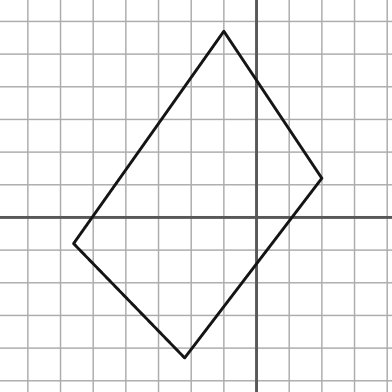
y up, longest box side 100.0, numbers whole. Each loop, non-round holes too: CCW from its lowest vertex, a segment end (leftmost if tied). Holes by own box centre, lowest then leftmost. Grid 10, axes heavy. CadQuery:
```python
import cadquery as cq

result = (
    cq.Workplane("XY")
    .moveTo(-22.0, -43.0)
    .lineTo(20.0, 12.0)
    .lineTo(-10.0, 57.0)
    .lineTo(-56.0, -8.0)
    .close()
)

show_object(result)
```